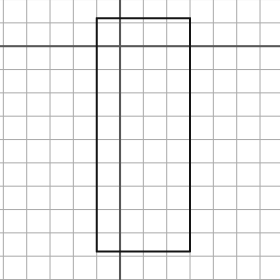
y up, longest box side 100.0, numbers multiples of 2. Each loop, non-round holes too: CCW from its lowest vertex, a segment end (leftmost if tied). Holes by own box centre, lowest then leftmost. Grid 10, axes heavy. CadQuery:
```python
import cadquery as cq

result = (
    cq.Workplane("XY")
    .moveTo(-10.0, -88.0)
    .lineTo(30.0, -88.0)
    .lineTo(30.0, 12.0)
    .lineTo(-10.0, 12.0)
    .close()
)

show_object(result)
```